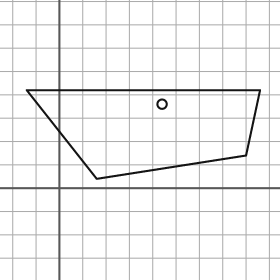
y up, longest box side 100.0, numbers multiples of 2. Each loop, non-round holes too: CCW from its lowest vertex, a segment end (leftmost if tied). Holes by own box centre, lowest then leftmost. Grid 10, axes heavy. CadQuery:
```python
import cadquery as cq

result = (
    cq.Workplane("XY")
    .moveTo(16.0, 4.0)
    .lineTo(80.0, 14.0)
    .lineTo(86.0, 42.0)
    .lineTo(-14.0, 42.0)
    .close()
    .moveTo(44.0, 36.0)
    .circle(2.0)
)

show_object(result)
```